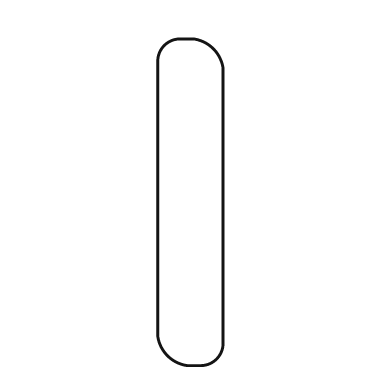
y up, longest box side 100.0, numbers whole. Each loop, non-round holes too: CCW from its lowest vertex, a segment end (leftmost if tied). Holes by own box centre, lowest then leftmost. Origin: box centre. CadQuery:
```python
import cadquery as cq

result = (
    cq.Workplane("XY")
    .moveTo(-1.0, -50.0)
    .lineTo(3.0, -50.0)
    .threePointArc((8.0, -48.0), (10.0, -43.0))
    .lineTo(10.0, 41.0)
    .threePointArc((7.0, 47.0), (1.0, 50.0))
    .lineTo(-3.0, 50.0)
    .threePointArc((-8.0, 48.0), (-10.0, 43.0))
    .lineTo(-10.0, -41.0)
    .threePointArc((-7.0, -47.0), (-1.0, -50.0))
    .close()
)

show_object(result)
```